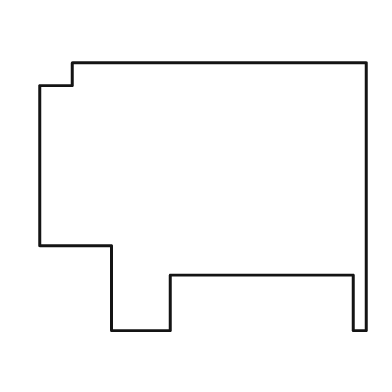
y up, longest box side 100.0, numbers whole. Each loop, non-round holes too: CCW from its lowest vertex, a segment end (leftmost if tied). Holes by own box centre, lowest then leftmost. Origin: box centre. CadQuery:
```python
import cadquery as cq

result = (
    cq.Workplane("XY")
    .moveTo(-28.0, -41.0)
    .lineTo(-10.0, -41.0)
    .lineTo(-10.0, -24.0)
    .lineTo(46.0, -24.0)
    .lineTo(46.0, -41.0)
    .lineTo(50.0, -41.0)
    .lineTo(50.0, 41.0)
    .lineTo(-40.0, 41.0)
    .lineTo(-40.0, 34.0)
    .lineTo(-50.0, 34.0)
    .lineTo(-50.0, -15.0)
    .lineTo(-28.0, -15.0)
    .close()
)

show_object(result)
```